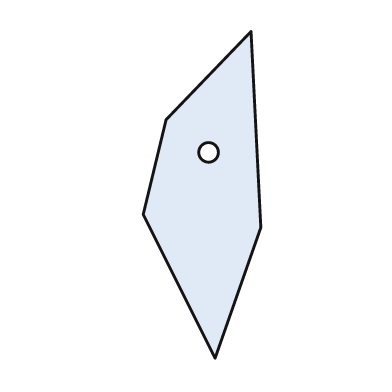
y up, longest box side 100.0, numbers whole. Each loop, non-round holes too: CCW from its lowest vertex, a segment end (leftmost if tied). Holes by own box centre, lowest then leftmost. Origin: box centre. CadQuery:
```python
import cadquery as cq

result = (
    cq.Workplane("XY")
    .moveTo(4.0, -50.0)
    .lineTo(18.0, -10.0)
    .lineTo(15.0, 50.0)
    .lineTo(-11.0, 23.0)
    .lineTo(-18.0, -6.0)
    .close()
    .moveTo(2.0, 13.0)
    .circle(3.0)
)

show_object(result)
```